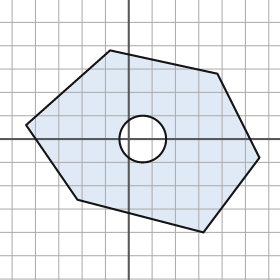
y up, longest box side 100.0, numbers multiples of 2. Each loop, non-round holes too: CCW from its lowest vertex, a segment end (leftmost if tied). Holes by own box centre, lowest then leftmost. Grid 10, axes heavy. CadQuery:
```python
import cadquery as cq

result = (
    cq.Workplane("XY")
    .moveTo(32.0, -40.0)
    .lineTo(56.0, -8.0)
    .lineTo(38.0, 28.0)
    .lineTo(-8.0, 38.0)
    .lineTo(-44.0, 6.0)
    .lineTo(-22.0, -26.0)
    .close()
    .moveTo(6.0, 0.0)
    .circle(10.0)
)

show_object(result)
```